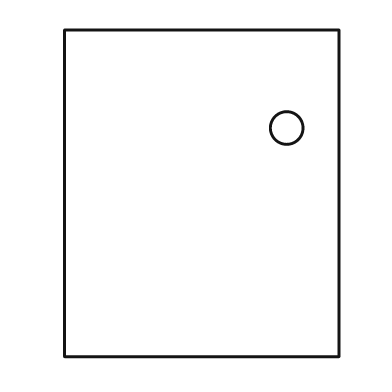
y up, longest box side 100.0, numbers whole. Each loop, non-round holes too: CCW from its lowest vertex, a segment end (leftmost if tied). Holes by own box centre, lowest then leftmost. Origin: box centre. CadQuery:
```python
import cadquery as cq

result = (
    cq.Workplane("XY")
    .moveTo(-42.0, -50.0)
    .lineTo(42.0, -50.0)
    .lineTo(42.0, 50.0)
    .lineTo(-42.0, 50.0)
    .close()
    .moveTo(26.0, 20.0)
    .circle(5.0)
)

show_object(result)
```